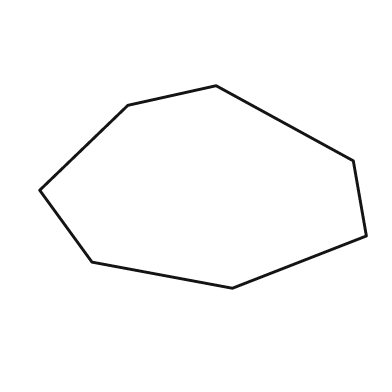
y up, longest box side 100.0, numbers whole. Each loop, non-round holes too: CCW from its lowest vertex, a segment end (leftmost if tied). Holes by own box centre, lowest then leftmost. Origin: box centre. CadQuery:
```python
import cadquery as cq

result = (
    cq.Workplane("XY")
    .moveTo(9.0, -31.0)
    .lineTo(50.0, -15.0)
    .lineTo(46.0, 8.0)
    .lineTo(4.0, 31.0)
    .lineTo(-23.0, 25.0)
    .lineTo(-50.0, -1.0)
    .lineTo(-34.0, -23.0)
    .close()
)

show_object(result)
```